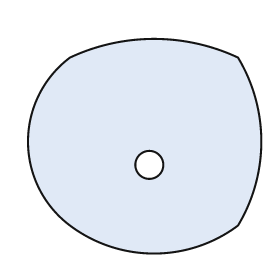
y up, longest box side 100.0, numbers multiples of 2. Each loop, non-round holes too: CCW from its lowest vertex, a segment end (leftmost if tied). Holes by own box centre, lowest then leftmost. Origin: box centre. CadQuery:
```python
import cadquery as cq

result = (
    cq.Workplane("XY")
    .moveTo(-32.0, -34.0)
    .threePointArc((4.0, -46.0), (40.0, -34.0))
    .threePointArc((50.0, 2.0), (40.0, 38.0))
    .threePointArc((4.0, 46.0), (-32.0, 38.0))
    .threePointArc((-50.0, 2.0), (-32.0, -34.0))
    .close()
    .moveTo(2.0, -8.0)
    .circle(6.0)
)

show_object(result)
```